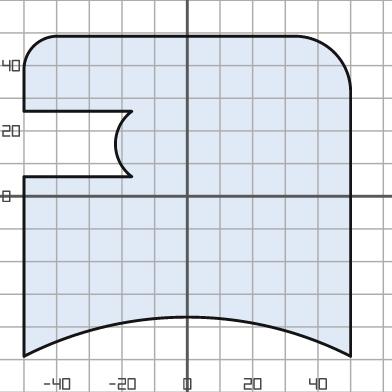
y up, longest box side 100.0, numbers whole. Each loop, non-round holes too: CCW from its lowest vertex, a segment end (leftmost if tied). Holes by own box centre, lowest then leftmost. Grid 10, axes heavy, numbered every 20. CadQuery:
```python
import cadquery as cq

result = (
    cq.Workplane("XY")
    .moveTo(-50.0, -49.0)
    .threePointArc((0.0, -37.0), (50.0, -49.0))
    .lineTo(50.0, 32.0)
    .threePointArc((45.0, 44.0), (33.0, 49.0))
    .lineTo(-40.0, 49.0)
    .threePointArc((-47.0, 46.0), (-50.0, 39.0))
    .lineTo(-50.0, 26.0)
    .lineTo(-17.0, 26.0)
    .threePointArc((-22.0, 16.0), (-17.0, 6.0))
    .lineTo(-50.0, 6.0)
    .close()
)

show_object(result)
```